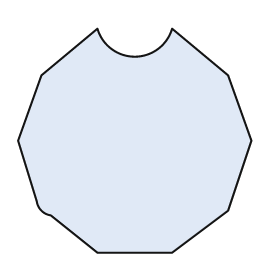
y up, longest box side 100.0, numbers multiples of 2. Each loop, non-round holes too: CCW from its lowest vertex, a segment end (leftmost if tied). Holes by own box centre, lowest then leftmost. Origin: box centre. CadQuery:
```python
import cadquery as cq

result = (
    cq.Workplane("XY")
    .moveTo(-16.0, -48.0)
    .lineTo(16.0, -48.0)
    .lineTo(40.0, -30.0)
    .lineTo(50.0, 0.0)
    .lineTo(40.0, 28.0)
    .lineTo(16.0, 48.0)
    .threePointArc((0.0, 36.0), (-16.0, 48.0))
    .lineTo(-40.0, 28.0)
    .lineTo(-50.0, 0.0)
    .lineTo(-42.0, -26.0)
    .threePointArc((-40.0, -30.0), (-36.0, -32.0))
    .close()
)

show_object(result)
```